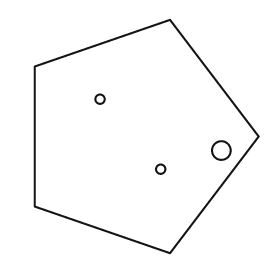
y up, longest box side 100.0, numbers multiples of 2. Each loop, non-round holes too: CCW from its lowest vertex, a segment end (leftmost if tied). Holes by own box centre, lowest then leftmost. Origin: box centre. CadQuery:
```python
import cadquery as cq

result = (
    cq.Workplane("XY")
    .moveTo(10.0, -50.0)
    .lineTo(48.0, 0.0)
    .lineTo(10.0, 50.0)
    .lineTo(-48.0, 30.0)
    .lineTo(-48.0, -30.0)
    .close()
    .moveTo(6.0, -14.0)
    .circle(2.0)
    .moveTo(32.0, -6.0)
    .circle(4.0)
    .moveTo(-20.0, 16.0)
    .circle(2.0)
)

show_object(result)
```